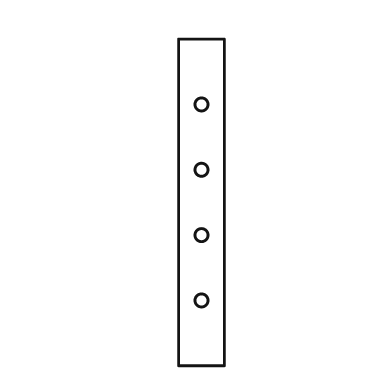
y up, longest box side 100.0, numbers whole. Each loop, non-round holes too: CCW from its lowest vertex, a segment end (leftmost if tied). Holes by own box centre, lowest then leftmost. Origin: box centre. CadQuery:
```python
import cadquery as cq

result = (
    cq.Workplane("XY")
    .moveTo(-7.0, -50.0)
    .lineTo(7.0, -50.0)
    .lineTo(7.0, 50.0)
    .lineTo(-7.0, 50.0)
    .close()
    .moveTo(0.0, -30.0)
    .circle(2.0)
    .moveTo(0.0, -10.0)
    .circle(2.0)
    .moveTo(0.0, 10.0)
    .circle(2.0)
    .moveTo(0.0, 30.0)
    .circle(2.0)
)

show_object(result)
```